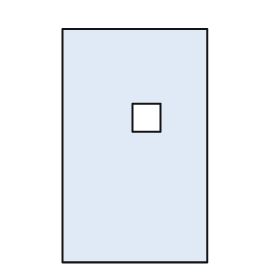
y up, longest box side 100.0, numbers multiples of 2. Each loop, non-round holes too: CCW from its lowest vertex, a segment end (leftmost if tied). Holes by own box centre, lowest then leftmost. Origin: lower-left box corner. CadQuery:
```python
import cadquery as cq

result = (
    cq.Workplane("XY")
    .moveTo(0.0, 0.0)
    .lineTo(62.0, 0.0)
    .lineTo(62.0, 100.0)
    .lineTo(0.0, 100.0)
    .close()
    .moveTo(30.0, 56.0)
    .lineTo(42.0, 56.0)
    .lineTo(42.0, 68.0)
    .lineTo(30.0, 68.0)
    .close()
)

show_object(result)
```